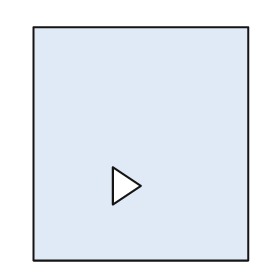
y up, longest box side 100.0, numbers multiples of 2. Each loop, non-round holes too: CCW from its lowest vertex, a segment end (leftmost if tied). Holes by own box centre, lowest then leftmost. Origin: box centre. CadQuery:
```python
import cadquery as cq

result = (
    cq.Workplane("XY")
    .moveTo(-46.0, -50.0)
    .lineTo(46.0, -50.0)
    .lineTo(46.0, 50.0)
    .lineTo(-46.0, 50.0)
    .close()
    .moveTo(-12.0, -26.0)
    .lineTo(0.0, -18.0)
    .lineTo(-12.0, -10.0)
    .close()
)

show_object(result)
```